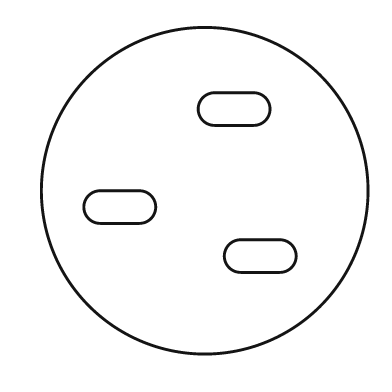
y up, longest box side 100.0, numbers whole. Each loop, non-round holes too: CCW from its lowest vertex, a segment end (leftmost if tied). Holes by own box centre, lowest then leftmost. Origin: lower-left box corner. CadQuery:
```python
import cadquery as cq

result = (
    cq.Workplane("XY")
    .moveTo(50.0, 50.0)
    .circle(50.0)
    .moveTo(61.0, 25.0)
    .lineTo(73.0, 25.0)
    .threePointArc((78.0, 30.0), (73.0, 35.0))
    .lineTo(61.0, 35.0)
    .threePointArc((56.0, 30.0), (61.0, 25.0))
    .close()
    .moveTo(18.0, 40.0)
    .lineTo(30.0, 40.0)
    .threePointArc((35.0, 45.0), (30.0, 50.0))
    .lineTo(18.0, 50.0)
    .threePointArc((13.0, 45.0), (18.0, 40.0))
    .close()
    .moveTo(53.0, 70.0)
    .lineTo(65.0, 70.0)
    .threePointArc((70.0, 75.0), (65.0, 80.0))
    .lineTo(53.0, 80.0)
    .threePointArc((48.0, 75.0), (53.0, 70.0))
    .close()
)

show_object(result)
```